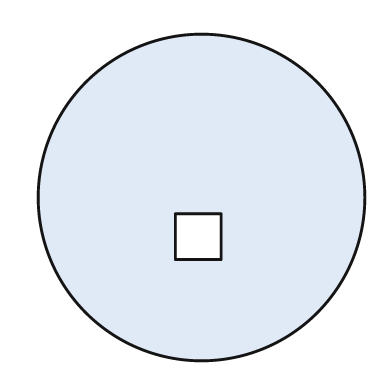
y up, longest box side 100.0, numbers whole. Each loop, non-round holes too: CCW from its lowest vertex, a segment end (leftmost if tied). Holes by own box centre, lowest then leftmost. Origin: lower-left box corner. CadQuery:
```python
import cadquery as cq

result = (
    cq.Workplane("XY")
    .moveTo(50.0, 50.0)
    .circle(50.0)
    .moveTo(42.0, 31.0)
    .lineTo(56.0, 31.0)
    .lineTo(56.0, 45.0)
    .lineTo(42.0, 45.0)
    .close()
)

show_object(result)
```